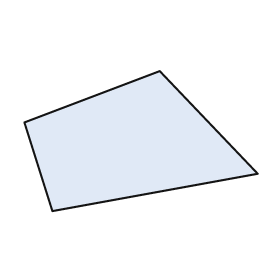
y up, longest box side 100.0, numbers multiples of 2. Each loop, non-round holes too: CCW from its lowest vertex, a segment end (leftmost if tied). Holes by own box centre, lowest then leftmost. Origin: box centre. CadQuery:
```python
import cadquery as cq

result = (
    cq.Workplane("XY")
    .moveTo(-38.0, -30.0)
    .lineTo(50.0, -14.0)
    .lineTo(8.0, 30.0)
    .lineTo(-50.0, 8.0)
    .close()
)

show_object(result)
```